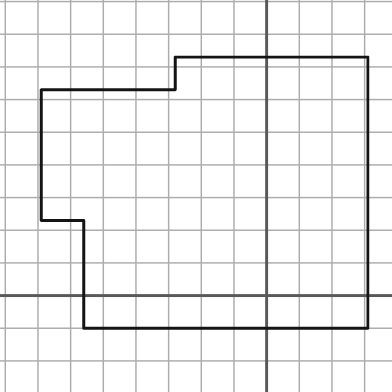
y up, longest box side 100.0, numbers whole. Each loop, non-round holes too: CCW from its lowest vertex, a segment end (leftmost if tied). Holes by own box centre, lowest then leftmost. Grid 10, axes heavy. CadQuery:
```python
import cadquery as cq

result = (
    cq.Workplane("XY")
    .moveTo(-56.0, -10.0)
    .lineTo(31.0, -10.0)
    .lineTo(31.0, 73.0)
    .lineTo(-28.0, 73.0)
    .lineTo(-28.0, 63.0)
    .lineTo(-69.0, 63.0)
    .lineTo(-69.0, 23.0)
    .lineTo(-56.0, 23.0)
    .close()
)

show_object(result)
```